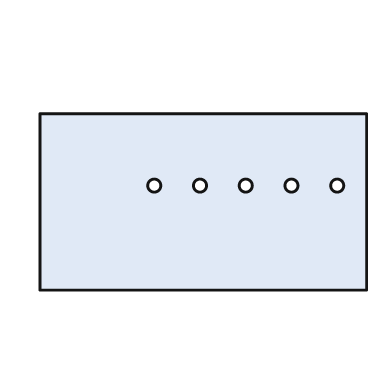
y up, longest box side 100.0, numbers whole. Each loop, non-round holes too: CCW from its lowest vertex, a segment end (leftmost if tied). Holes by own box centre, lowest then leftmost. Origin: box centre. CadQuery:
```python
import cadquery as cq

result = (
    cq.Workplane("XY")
    .moveTo(-50.0, -27.0)
    .lineTo(50.0, -27.0)
    .lineTo(50.0, 27.0)
    .lineTo(-50.0, 27.0)
    .close()
    .moveTo(-15.0, 5.0)
    .circle(2.0)
    .moveTo(-1.0, 5.0)
    .circle(2.0)
    .moveTo(13.0, 5.0)
    .circle(2.0)
    .moveTo(27.0, 5.0)
    .circle(2.0)
    .moveTo(41.0, 5.0)
    .circle(2.0)
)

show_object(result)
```